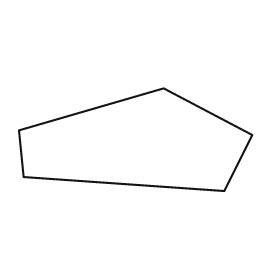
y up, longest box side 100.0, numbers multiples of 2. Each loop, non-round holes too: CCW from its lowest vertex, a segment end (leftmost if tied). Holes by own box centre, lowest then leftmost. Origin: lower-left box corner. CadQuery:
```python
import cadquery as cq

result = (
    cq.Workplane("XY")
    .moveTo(88.0, 0.0)
    .lineTo(100.0, 24.0)
    .lineTo(62.0, 44.0)
    .lineTo(0.0, 26.0)
    .lineTo(2.0, 6.0)
    .close()
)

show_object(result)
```